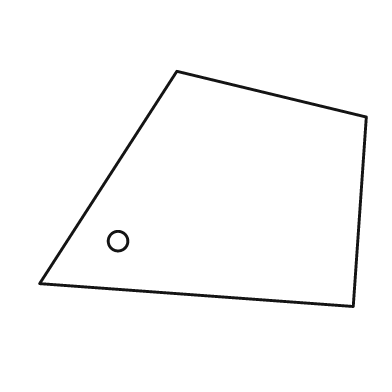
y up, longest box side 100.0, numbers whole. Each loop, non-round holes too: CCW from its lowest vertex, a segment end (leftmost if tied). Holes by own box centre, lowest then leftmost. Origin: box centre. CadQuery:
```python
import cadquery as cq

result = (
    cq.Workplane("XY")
    .moveTo(46.0, -36.0)
    .lineTo(50.0, 22.0)
    .lineTo(-8.0, 36.0)
    .lineTo(-50.0, -29.0)
    .close()
    .moveTo(-26.0, -16.0)
    .circle(3.0)
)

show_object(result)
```